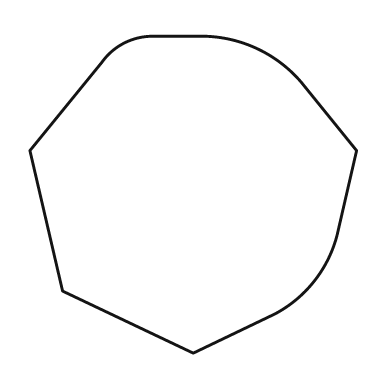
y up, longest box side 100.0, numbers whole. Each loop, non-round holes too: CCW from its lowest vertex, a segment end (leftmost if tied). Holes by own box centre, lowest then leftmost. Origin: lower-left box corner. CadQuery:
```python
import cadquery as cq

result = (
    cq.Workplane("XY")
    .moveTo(50.0, 0.0)
    .lineTo(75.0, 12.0)
    .threePointArc((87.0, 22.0), (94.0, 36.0))
    .lineTo(100.0, 62.0)
    .lineTo(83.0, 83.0)
    .threePointArc((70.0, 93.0), (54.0, 97.0))
    .lineTo(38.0, 97.0)
    .threePointArc((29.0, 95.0), (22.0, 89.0))
    .lineTo(0.0, 62.0)
    .lineTo(10.0, 19.0)
    .close()
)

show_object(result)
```